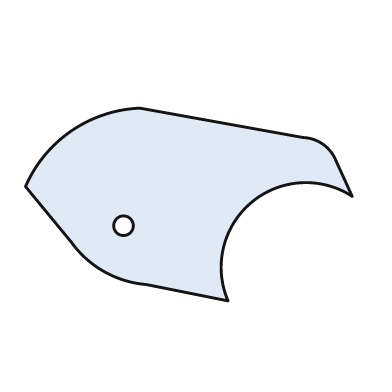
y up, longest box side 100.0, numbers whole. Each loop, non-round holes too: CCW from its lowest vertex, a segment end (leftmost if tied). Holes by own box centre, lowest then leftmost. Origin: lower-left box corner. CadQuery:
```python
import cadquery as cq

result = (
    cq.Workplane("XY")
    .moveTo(62.0, 0.0)
    .threePointArc((69.0, 30.0), (100.0, 32.0))
    .lineTo(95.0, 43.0)
    .threePointArc((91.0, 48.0), (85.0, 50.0))
    .lineTo(35.0, 59.0)
    .threePointArc((14.0, 52.0), (0.0, 35.0))
    .lineTo(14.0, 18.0)
    .threePointArc((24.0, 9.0), (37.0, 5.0))
    .close()
    .moveTo(30.0, 23.0)
    .circle(3.0)
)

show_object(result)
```